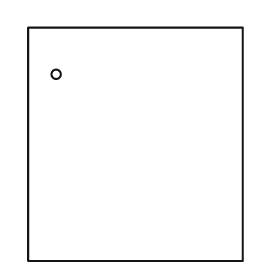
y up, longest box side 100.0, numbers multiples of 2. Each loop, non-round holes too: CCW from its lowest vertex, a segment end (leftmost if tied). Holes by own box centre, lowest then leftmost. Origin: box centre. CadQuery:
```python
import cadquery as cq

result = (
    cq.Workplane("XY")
    .moveTo(-46.0, -50.0)
    .lineTo(46.0, -50.0)
    .lineTo(46.0, 50.0)
    .lineTo(-46.0, 50.0)
    .close()
    .moveTo(-34.0, 30.0)
    .circle(2.0)
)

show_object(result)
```